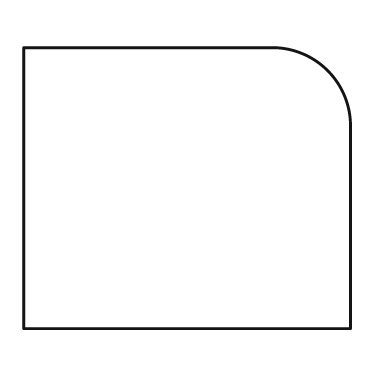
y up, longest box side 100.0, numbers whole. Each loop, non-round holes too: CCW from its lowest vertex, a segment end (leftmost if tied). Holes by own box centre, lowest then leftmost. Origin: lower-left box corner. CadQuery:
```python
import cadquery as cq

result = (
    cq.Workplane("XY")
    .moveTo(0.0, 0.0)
    .lineTo(100.0, 0.0)
    .lineTo(100.0, 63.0)
    .threePointArc((93.0, 79.0), (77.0, 86.0))
    .lineTo(0.0, 86.0)
    .close()
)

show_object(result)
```